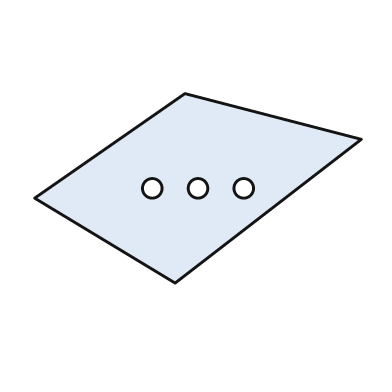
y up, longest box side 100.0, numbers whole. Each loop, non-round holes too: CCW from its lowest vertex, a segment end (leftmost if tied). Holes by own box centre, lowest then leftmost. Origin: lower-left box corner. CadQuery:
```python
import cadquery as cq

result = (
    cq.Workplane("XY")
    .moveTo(43.0, 0.0)
    .lineTo(100.0, 44.0)
    .lineTo(46.0, 58.0)
    .lineTo(0.0, 26.0)
    .close()
    .moveTo(36.0, 29.0)
    .circle(3.0)
    .moveTo(50.0, 29.0)
    .circle(3.0)
    .moveTo(64.0, 29.0)
    .circle(3.0)
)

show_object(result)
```